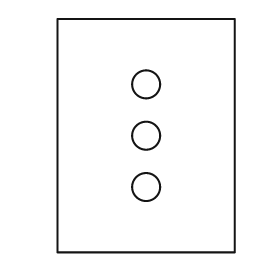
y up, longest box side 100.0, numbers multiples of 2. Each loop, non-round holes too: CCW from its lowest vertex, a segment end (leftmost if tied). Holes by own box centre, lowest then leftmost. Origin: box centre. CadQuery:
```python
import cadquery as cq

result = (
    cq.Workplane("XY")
    .moveTo(-38.0, -50.0)
    .lineTo(38.0, -50.0)
    .lineTo(38.0, 50.0)
    .lineTo(-38.0, 50.0)
    .close()
    .moveTo(0.0, -22.0)
    .circle(6.0)
    .moveTo(0.0, 0.0)
    .circle(6.0)
    .moveTo(0.0, 22.0)
    .circle(6.0)
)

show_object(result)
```